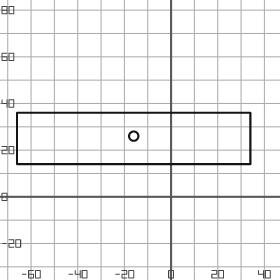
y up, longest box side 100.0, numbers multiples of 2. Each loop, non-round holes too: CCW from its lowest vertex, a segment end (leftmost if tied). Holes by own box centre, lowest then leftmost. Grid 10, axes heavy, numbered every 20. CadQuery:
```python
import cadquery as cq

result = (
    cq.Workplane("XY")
    .moveTo(-66.0, 14.0)
    .lineTo(34.0, 14.0)
    .lineTo(34.0, 36.0)
    .lineTo(-66.0, 36.0)
    .close()
    .moveTo(-16.0, 26.0)
    .circle(2.0)
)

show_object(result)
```